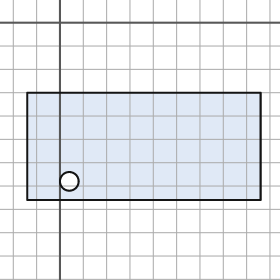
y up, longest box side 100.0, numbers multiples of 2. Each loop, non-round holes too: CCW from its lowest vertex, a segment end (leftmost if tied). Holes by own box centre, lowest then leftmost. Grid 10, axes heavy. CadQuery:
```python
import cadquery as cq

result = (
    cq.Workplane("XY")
    .moveTo(-14.0, -76.0)
    .lineTo(86.0, -76.0)
    .lineTo(86.0, -30.0)
    .lineTo(-14.0, -30.0)
    .close()
    .moveTo(4.0, -68.0)
    .circle(4.0)
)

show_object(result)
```